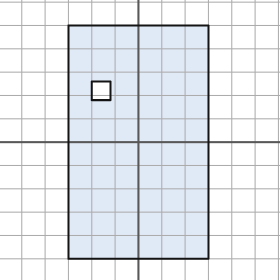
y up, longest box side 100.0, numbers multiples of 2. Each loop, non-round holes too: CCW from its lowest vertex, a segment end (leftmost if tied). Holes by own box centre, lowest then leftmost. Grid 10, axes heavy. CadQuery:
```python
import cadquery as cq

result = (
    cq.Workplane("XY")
    .moveTo(-30.0, -50.0)
    .lineTo(30.0, -50.0)
    .lineTo(30.0, 50.0)
    .lineTo(-30.0, 50.0)
    .close()
    .moveTo(-20.0, 18.0)
    .lineTo(-12.0, 18.0)
    .lineTo(-12.0, 26.0)
    .lineTo(-20.0, 26.0)
    .close()
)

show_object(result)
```